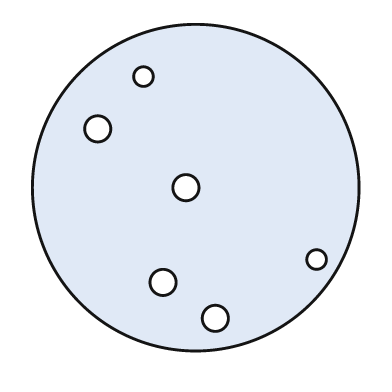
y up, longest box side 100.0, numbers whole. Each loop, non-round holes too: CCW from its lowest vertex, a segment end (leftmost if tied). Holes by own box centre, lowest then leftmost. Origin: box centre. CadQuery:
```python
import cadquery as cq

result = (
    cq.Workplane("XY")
    .moveTo(0.0, 0.0)
    .circle(50.0)
    .moveTo(6.0, -40.0)
    .circle(4.0)
    .moveTo(-10.0, -29.0)
    .circle(4.0)
    .moveTo(37.0, -22.0)
    .circle(3.0)
    .moveTo(-3.0, 0.0)
    .circle(4.0)
    .moveTo(-30.0, 18.0)
    .circle(4.0)
    .moveTo(-16.0, 34.0)
    .circle(3.0)
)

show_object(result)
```